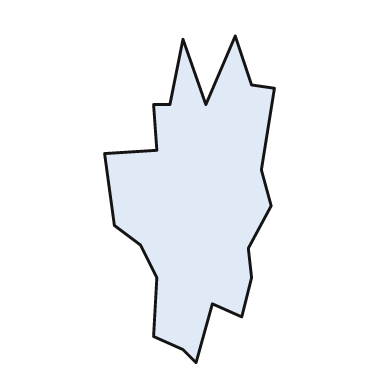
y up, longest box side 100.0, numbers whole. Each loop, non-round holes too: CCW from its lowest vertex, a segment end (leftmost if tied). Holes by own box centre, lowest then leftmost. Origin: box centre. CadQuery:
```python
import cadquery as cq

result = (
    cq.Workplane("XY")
    .moveTo(2.0, -50.0)
    .lineTo(7.0, -32.0)
    .lineTo(16.0, -36.0)
    .lineTo(19.0, -24.0)
    .lineTo(18.0, -15.0)
    .lineTo(25.0, -2.0)
    .lineTo(22.0, 9.0)
    .lineTo(26.0, 34.0)
    .lineTo(19.0, 35.0)
    .lineTo(14.0, 50.0)
    .lineTo(5.0, 29.0)
    .lineTo(-2.0, 49.0)
    .lineTo(-6.0, 29.0)
    .lineTo(-11.0, 29.0)
    .lineTo(-10.0, 15.0)
    .lineTo(-26.0, 14.0)
    .lineTo(-23.0, -8.0)
    .lineTo(-15.0, -14.0)
    .lineTo(-10.0, -24.0)
    .lineTo(-11.0, -42.0)
    .lineTo(-2.0, -46.0)
    .close()
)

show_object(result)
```